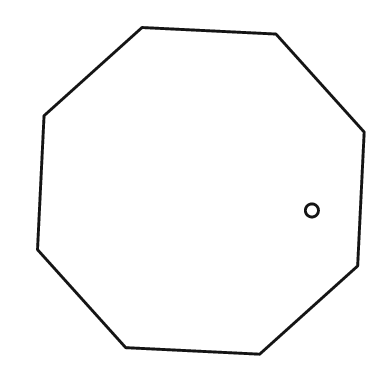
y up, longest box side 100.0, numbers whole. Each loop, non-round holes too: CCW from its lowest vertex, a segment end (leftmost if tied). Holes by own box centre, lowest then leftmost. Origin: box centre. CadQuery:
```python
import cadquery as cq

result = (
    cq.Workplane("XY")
    .moveTo(18.0, -50.0)
    .lineTo(48.0, -23.0)
    .lineTo(50.0, 18.0)
    .lineTo(23.0, 48.0)
    .lineTo(-18.0, 50.0)
    .lineTo(-48.0, 23.0)
    .lineTo(-50.0, -18.0)
    .lineTo(-23.0, -48.0)
    .close()
    .moveTo(34.0, -6.0)
    .circle(2.0)
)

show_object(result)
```